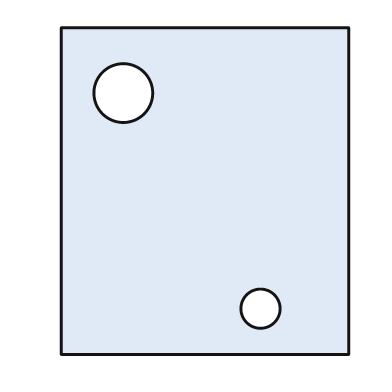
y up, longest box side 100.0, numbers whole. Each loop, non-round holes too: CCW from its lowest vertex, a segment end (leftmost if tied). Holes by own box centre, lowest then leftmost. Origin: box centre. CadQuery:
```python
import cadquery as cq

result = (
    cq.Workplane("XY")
    .moveTo(-44.0, -50.0)
    .lineTo(44.0, -50.0)
    .lineTo(44.0, 50.0)
    .lineTo(-44.0, 50.0)
    .close()
    .moveTo(17.0, -36.0)
    .circle(6.0)
    .moveTo(-25.0, 30.0)
    .circle(9.0)
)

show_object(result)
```